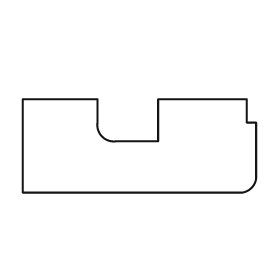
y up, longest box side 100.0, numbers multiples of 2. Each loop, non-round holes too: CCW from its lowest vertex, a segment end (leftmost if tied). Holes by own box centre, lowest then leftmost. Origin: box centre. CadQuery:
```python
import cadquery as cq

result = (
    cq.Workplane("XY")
    .moveTo(-50.0, -20.0)
    .lineTo(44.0, -20.0)
    .threePointArc((48.0, -18.0), (50.0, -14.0))
    .lineTo(50.0, 10.0)
    .lineTo(46.0, 10.0)
    .lineTo(46.0, 20.0)
    .lineTo(8.0, 20.0)
    .lineTo(8.0, 2.0)
    .lineTo(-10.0, 2.0)
    .threePointArc((-16.0, 4.0), (-18.0, 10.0))
    .lineTo(-18.0, 20.0)
    .lineTo(-50.0, 20.0)
    .close()
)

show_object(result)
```